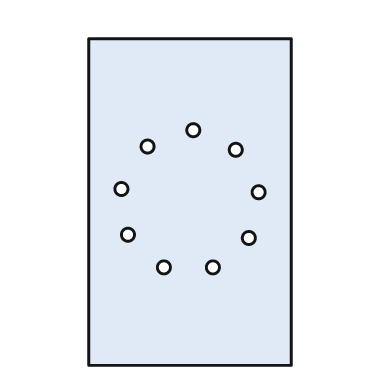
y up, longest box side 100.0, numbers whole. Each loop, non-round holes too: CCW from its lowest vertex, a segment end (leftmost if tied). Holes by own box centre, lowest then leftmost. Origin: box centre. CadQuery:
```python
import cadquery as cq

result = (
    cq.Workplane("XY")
    .moveTo(-31.0, -50.0)
    .lineTo(31.0, -50.0)
    .lineTo(31.0, 50.0)
    .lineTo(-31.0, 50.0)
    .close()
    .moveTo(-8.0, -20.0)
    .circle(2.0)
    .moveTo(7.0, -20.0)
    .circle(2.0)
    .moveTo(18.0, -11.0)
    .circle(2.0)
    .moveTo(-19.0, -10.0)
    .circle(2.0)
    .moveTo(21.0, 3.0)
    .circle(2.0)
    .moveTo(-21.0, 4.0)
    .circle(2.0)
    .moveTo(14.0, 16.0)
    .circle(2.0)
    .moveTo(-13.0, 17.0)
    .circle(2.0)
    .moveTo(1.0, 22.0)
    .circle(2.0)
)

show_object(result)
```